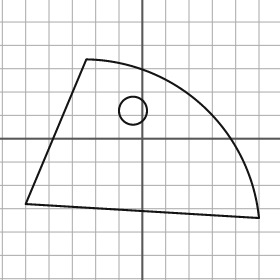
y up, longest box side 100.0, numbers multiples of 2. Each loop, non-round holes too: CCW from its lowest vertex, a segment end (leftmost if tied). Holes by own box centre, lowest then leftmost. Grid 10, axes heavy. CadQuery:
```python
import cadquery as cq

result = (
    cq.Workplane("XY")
    .moveTo(50.0, -34.0)
    .threePointArc((26.0, 14.0), (-24.0, 34.0))
    .lineTo(-50.0, -28.0)
    .close()
    .moveTo(-4.0, 12.0)
    .circle(6.0)
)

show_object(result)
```